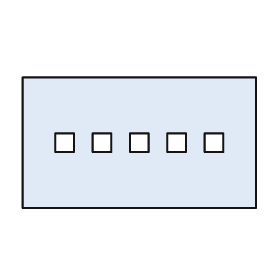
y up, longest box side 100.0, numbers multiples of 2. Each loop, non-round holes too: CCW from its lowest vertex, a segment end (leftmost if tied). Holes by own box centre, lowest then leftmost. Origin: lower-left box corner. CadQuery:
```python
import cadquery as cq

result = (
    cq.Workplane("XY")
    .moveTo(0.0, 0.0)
    .lineTo(100.0, 0.0)
    .lineTo(100.0, 56.0)
    .lineTo(0.0, 56.0)
    .close()
    .moveTo(14.0, 24.0)
    .lineTo(22.0, 24.0)
    .lineTo(22.0, 32.0)
    .lineTo(14.0, 32.0)
    .close()
    .moveTo(30.0, 24.0)
    .lineTo(38.0, 24.0)
    .lineTo(38.0, 32.0)
    .lineTo(30.0, 32.0)
    .close()
    .moveTo(46.0, 24.0)
    .lineTo(54.0, 24.0)
    .lineTo(54.0, 32.0)
    .lineTo(46.0, 32.0)
    .close()
    .moveTo(62.0, 24.0)
    .lineTo(70.0, 24.0)
    .lineTo(70.0, 32.0)
    .lineTo(62.0, 32.0)
    .close()
    .moveTo(78.0, 24.0)
    .lineTo(86.0, 24.0)
    .lineTo(86.0, 32.0)
    .lineTo(78.0, 32.0)
    .close()
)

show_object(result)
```